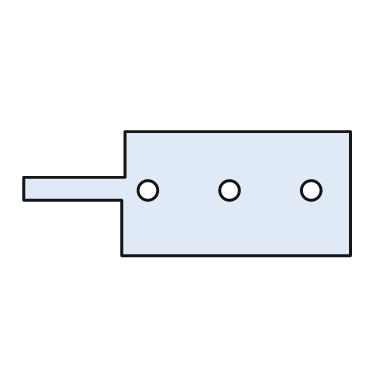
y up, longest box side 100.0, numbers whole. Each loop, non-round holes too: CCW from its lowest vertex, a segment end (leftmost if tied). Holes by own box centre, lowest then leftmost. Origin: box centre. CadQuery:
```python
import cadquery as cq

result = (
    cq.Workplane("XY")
    .moveTo(-20.0, -19.0)
    .lineTo(50.0, -19.0)
    .lineTo(50.0, 19.0)
    .lineTo(-19.0, 19.0)
    .lineTo(-19.0, 5.0)
    .lineTo(-50.0, 5.0)
    .lineTo(-50.0, -2.0)
    .lineTo(-20.0, -2.0)
    .close()
    .moveTo(-12.0, 1.0)
    .circle(3.0)
    .moveTo(13.0, 1.0)
    .circle(3.0)
    .moveTo(38.0, 1.0)
    .circle(3.0)
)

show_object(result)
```